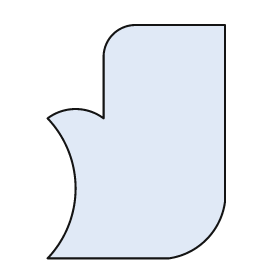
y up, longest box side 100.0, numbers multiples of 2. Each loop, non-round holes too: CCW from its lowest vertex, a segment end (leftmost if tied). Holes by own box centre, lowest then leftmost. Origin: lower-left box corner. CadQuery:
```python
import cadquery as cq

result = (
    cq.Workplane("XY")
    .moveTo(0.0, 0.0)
    .lineTo(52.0, 0.0)
    .threePointArc((68.0, 8.0), (76.0, 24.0))
    .lineTo(76.0, 100.0)
    .lineTo(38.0, 100.0)
    .threePointArc((28.0, 96.0), (24.0, 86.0))
    .lineTo(24.0, 60.0)
    .threePointArc((12.0, 64.0), (0.0, 60.0))
    .threePointArc((12.0, 30.0), (0.0, 0.0))
    .close()
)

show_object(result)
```